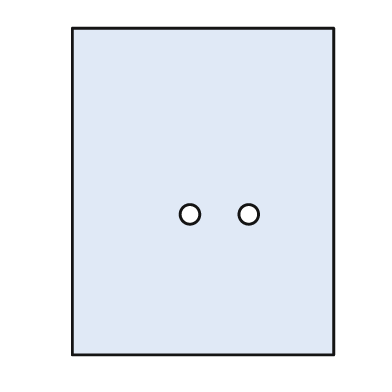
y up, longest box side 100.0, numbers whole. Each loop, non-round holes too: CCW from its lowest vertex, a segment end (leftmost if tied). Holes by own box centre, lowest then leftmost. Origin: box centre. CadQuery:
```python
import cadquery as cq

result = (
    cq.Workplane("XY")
    .moveTo(-40.0, -50.0)
    .lineTo(40.0, -50.0)
    .lineTo(40.0, 50.0)
    .lineTo(-40.0, 50.0)
    .close()
    .moveTo(-4.0, -7.0)
    .circle(3.0)
    .moveTo(14.0, -7.0)
    .circle(3.0)
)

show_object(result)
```